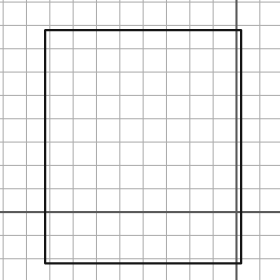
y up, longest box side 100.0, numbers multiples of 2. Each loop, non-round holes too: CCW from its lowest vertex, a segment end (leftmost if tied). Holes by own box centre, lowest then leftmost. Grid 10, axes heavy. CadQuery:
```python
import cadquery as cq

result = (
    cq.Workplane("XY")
    .moveTo(-82.0, -22.0)
    .lineTo(2.0, -22.0)
    .lineTo(2.0, 78.0)
    .lineTo(-82.0, 78.0)
    .close()
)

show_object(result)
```